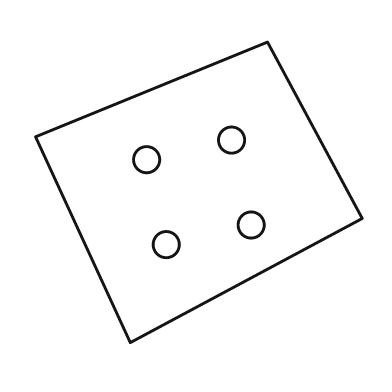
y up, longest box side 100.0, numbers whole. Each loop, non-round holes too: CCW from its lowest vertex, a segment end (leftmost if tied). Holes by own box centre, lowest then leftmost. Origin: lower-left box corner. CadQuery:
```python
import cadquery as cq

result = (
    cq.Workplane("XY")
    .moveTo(29.0, 0.0)
    .lineTo(100.0, 38.0)
    .lineTo(71.0, 92.0)
    .lineTo(0.0, 63.0)
    .close()
    .moveTo(40.0, 30.0)
    .circle(4.0)
    .moveTo(66.0, 36.0)
    .circle(4.0)
    .moveTo(34.0, 56.0)
    .circle(4.0)
    .moveTo(60.0, 62.0)
    .circle(4.0)
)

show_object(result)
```